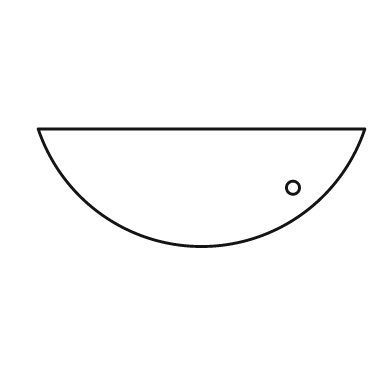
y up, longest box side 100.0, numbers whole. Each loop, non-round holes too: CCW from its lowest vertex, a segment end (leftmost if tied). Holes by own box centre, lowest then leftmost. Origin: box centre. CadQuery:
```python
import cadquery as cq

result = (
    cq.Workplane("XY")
    .moveTo(-50.0, 18.0)
    .threePointArc((0.0, -18.0), (50.0, 18.0))
    .close()
    .moveTo(28.0, 0.0)
    .circle(2.0)
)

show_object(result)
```